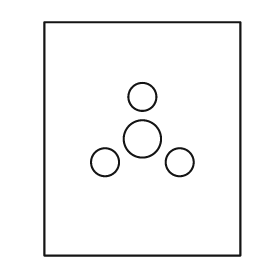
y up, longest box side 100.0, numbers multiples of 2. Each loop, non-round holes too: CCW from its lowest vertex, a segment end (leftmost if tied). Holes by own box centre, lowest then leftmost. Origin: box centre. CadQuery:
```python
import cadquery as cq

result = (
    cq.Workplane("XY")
    .moveTo(-42.0, -50.0)
    .lineTo(42.0, -50.0)
    .lineTo(42.0, 50.0)
    .lineTo(-42.0, 50.0)
    .close()
    .moveTo(-16.0, -10.0)
    .circle(6.0)
    .moveTo(16.0, -10.0)
    .circle(6.0)
    .moveTo(0.0, 0.0)
    .circle(8.0)
    .moveTo(0.0, 18.0)
    .circle(6.0)
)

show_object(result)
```